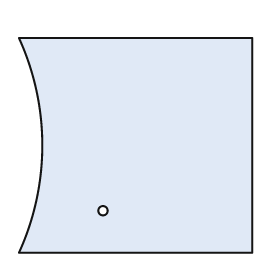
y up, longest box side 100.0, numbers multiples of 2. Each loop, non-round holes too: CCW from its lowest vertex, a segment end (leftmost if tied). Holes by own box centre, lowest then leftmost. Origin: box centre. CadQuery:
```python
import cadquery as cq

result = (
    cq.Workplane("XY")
    .moveTo(-50.0, -46.0)
    .lineTo(50.0, -46.0)
    .lineTo(50.0, 46.0)
    .lineTo(-50.0, 46.0)
    .threePointArc((-40.0, 0.0), (-50.0, -46.0))
    .close()
    .moveTo(-14.0, -28.0)
    .circle(2.0)
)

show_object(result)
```